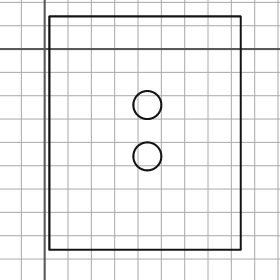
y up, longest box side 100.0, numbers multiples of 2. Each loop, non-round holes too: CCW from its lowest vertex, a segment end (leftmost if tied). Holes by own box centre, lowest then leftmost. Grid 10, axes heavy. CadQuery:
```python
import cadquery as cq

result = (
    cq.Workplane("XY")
    .moveTo(2.0, -86.0)
    .lineTo(84.0, -86.0)
    .lineTo(84.0, 14.0)
    .lineTo(2.0, 14.0)
    .close()
    .moveTo(44.0, -46.0)
    .circle(6.0)
    .moveTo(44.0, -24.0)
    .circle(6.0)
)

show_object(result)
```